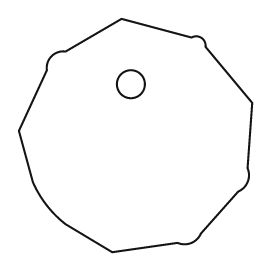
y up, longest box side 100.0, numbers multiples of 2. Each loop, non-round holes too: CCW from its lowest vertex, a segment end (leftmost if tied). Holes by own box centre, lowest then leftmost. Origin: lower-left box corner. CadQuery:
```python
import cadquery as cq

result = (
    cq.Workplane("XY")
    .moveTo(40.0, 0.0)
    .lineTo(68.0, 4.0)
    .threePointArc((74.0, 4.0), (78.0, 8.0))
    .lineTo(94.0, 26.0)
    .threePointArc((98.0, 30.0), (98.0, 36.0))
    .lineTo(100.0, 64.0)
    .lineTo(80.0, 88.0)
    .threePointArc((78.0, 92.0), (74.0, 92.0))
    .lineTo(44.0, 100.0)
    .lineTo(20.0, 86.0)
    .threePointArc((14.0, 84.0), (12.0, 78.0))
    .lineTo(0.0, 52.0)
    .lineTo(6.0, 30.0)
    .threePointArc((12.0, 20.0), (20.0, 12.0))
    .close()
    .moveTo(48.0, 72.0)
    .circle(6.0)
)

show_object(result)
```